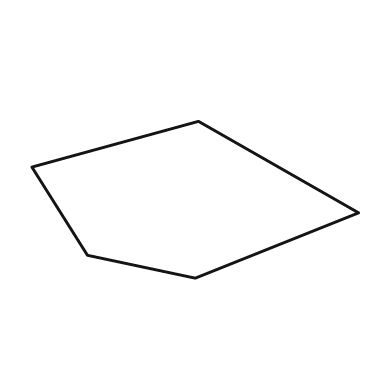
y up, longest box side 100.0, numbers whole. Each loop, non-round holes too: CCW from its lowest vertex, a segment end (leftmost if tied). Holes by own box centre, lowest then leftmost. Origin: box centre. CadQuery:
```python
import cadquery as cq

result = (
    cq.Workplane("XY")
    .moveTo(0.0, -24.0)
    .lineTo(50.0, -4.0)
    .lineTo(1.0, 24.0)
    .lineTo(-50.0, 10.0)
    .lineTo(-33.0, -17.0)
    .close()
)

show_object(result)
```